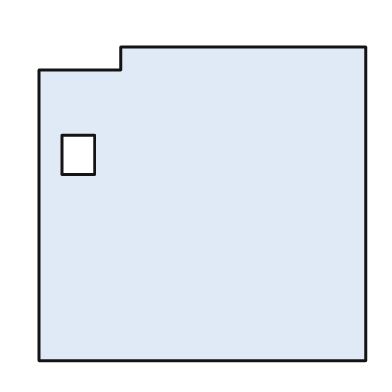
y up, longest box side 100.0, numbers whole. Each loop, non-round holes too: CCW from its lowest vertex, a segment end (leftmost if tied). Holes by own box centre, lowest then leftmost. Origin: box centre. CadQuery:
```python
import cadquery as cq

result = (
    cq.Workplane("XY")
    .moveTo(-50.0, -48.0)
    .lineTo(50.0, -48.0)
    .lineTo(50.0, 48.0)
    .lineTo(-25.0, 48.0)
    .lineTo(-25.0, 41.0)
    .lineTo(-50.0, 41.0)
    .close()
    .moveTo(-43.0, 9.0)
    .lineTo(-33.0, 9.0)
    .lineTo(-33.0, 21.0)
    .lineTo(-43.0, 21.0)
    .close()
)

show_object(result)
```